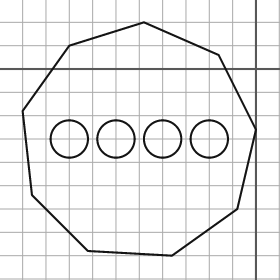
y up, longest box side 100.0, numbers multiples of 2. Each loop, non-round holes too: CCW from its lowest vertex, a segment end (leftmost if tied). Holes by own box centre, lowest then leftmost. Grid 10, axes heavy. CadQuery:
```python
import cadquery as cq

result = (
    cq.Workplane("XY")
    .moveTo(-36.0, -80.0)
    .lineTo(-8.0, -60.0)
    .lineTo(0.0, -26.0)
    .lineTo(-16.0, 6.0)
    .lineTo(-48.0, 20.0)
    .lineTo(-80.0, 10.0)
    .lineTo(-100.0, -18.0)
    .lineTo(-96.0, -54.0)
    .lineTo(-72.0, -78.0)
    .close()
    .moveTo(-80.0, -30.0)
    .circle(8.0)
    .moveTo(-60.0, -30.0)
    .circle(8.0)
    .moveTo(-40.0, -30.0)
    .circle(8.0)
    .moveTo(-20.0, -30.0)
    .circle(8.0)
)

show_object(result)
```